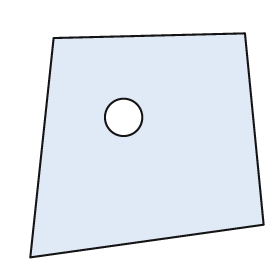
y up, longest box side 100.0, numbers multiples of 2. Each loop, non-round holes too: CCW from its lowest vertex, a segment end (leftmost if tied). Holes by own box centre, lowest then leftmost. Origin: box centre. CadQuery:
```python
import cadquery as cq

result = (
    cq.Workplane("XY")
    .moveTo(-50.0, -48.0)
    .lineTo(50.0, -34.0)
    .lineTo(42.0, 48.0)
    .lineTo(-40.0, 46.0)
    .close()
    .moveTo(-10.0, 12.0)
    .circle(8.0)
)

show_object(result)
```